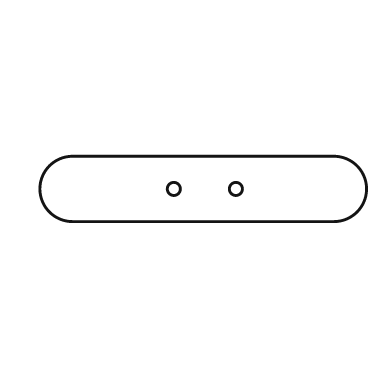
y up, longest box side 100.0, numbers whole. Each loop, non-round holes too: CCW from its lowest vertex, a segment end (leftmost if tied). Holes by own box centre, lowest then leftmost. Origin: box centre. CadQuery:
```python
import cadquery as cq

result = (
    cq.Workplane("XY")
    .moveTo(-40.0, -10.0)
    .lineTo(40.0, -10.0)
    .threePointArc((50.0, 0.0), (40.0, 10.0))
    .lineTo(-40.0, 10.0)
    .threePointArc((-50.0, 0.0), (-40.0, -10.0))
    .close()
    .moveTo(-9.0, 0.0)
    .circle(2.0)
    .moveTo(10.0, 0.0)
    .circle(2.0)
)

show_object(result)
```